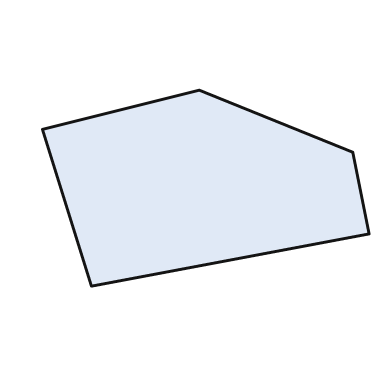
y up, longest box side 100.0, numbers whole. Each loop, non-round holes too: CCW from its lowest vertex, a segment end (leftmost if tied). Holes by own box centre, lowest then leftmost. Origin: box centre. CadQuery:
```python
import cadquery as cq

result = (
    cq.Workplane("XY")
    .moveTo(-35.0, -30.0)
    .lineTo(50.0, -14.0)
    .lineTo(45.0, 11.0)
    .lineTo(-2.0, 30.0)
    .lineTo(-50.0, 18.0)
    .close()
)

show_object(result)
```